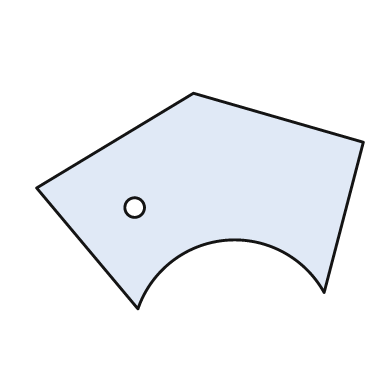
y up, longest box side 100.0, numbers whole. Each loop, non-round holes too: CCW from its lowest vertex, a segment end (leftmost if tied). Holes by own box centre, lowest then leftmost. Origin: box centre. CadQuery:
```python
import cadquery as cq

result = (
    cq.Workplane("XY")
    .moveTo(-19.0, -33.0)
    .threePointArc((8.0, -12.0), (38.0, -28.0))
    .lineTo(50.0, 18.0)
    .lineTo(-2.0, 33.0)
    .lineTo(-50.0, 4.0)
    .close()
    .moveTo(-20.0, -2.0)
    .circle(3.0)
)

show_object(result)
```